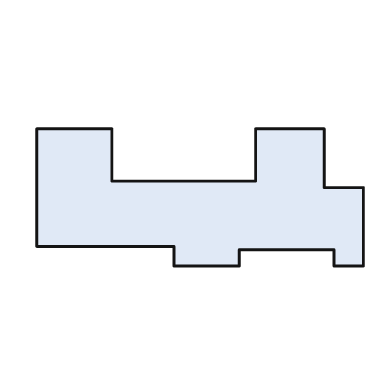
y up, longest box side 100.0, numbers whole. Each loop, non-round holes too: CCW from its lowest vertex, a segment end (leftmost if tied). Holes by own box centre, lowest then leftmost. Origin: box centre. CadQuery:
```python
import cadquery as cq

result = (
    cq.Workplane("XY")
    .moveTo(-8.0, -21.0)
    .lineTo(12.0, -21.0)
    .lineTo(12.0, -16.0)
    .lineTo(41.0, -16.0)
    .lineTo(41.0, -21.0)
    .lineTo(50.0, -21.0)
    .lineTo(50.0, 3.0)
    .lineTo(38.0, 3.0)
    .lineTo(38.0, 21.0)
    .lineTo(17.0, 21.0)
    .lineTo(17.0, 5.0)
    .lineTo(-27.0, 5.0)
    .lineTo(-27.0, 21.0)
    .lineTo(-50.0, 21.0)
    .lineTo(-50.0, -15.0)
    .lineTo(-8.0, -15.0)
    .close()
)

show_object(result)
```